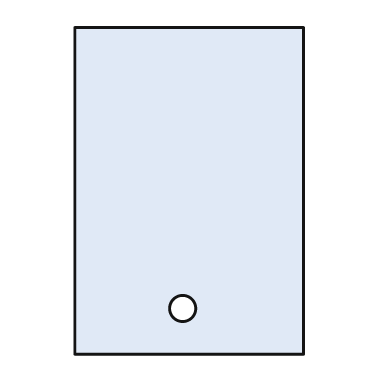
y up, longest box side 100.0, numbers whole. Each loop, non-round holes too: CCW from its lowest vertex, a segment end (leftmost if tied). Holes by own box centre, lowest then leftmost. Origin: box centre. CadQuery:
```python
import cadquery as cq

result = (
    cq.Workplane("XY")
    .moveTo(-35.0, -50.0)
    .lineTo(35.0, -50.0)
    .lineTo(35.0, 50.0)
    .lineTo(-35.0, 50.0)
    .close()
    .moveTo(-2.0, -36.0)
    .circle(4.0)
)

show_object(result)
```